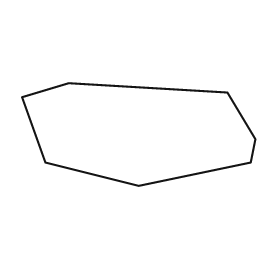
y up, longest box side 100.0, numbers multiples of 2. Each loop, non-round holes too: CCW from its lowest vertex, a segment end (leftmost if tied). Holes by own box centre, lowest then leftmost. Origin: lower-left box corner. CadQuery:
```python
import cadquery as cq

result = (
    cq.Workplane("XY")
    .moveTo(50.0, 0.0)
    .lineTo(98.0, 10.0)
    .lineTo(100.0, 20.0)
    .lineTo(88.0, 40.0)
    .lineTo(20.0, 44.0)
    .lineTo(0.0, 38.0)
    .lineTo(10.0, 10.0)
    .close()
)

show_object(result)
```